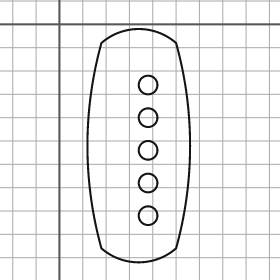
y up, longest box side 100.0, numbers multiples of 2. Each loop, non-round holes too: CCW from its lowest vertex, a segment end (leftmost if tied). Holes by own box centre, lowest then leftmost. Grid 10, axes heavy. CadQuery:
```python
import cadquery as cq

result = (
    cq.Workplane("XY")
    .moveTo(18.0, -96.0)
    .threePointArc((34.0, -102.0), (50.0, -96.0))
    .threePointArc((56.0, -52.0), (50.0, -8.0))
    .threePointArc((34.0, -2.0), (18.0, -8.0))
    .threePointArc((12.0, -52.0), (18.0, -96.0))
    .close()
    .moveTo(38.0, -82.0)
    .circle(4.0)
    .moveTo(38.0, -68.0)
    .circle(4.0)
    .moveTo(38.0, -54.0)
    .circle(4.0)
    .moveTo(38.0, -40.0)
    .circle(4.0)
    .moveTo(38.0, -26.0)
    .circle(4.0)
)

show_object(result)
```